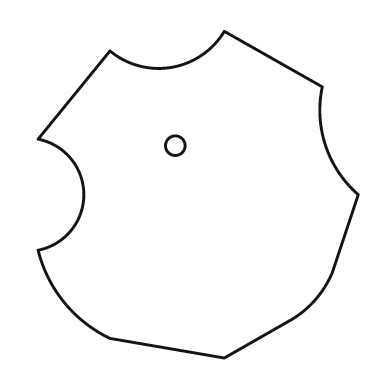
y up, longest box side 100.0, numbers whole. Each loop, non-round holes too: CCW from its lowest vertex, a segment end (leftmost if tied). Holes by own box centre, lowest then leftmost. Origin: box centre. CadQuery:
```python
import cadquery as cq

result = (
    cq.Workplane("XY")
    .moveTo(8.0, -50.0)
    .lineTo(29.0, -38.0)
    .threePointArc((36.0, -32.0), (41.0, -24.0))
    .lineTo(49.0, 0.0)
    .threePointArc((39.0, 15.0), (38.0, 33.0))
    .lineTo(8.0, 50.0)
    .threePointArc((-8.0, 39.0), (-27.0, 44.0))
    .lineTo(-49.0, 17.0)
    .threePointArc((-35.0, 0.0), (-49.0, -17.0))
    .threePointArc((-41.0, -33.0), (-27.0, -44.0))
    .close()
    .moveTo(-7.0, 15.0)
    .circle(3.0)
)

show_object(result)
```